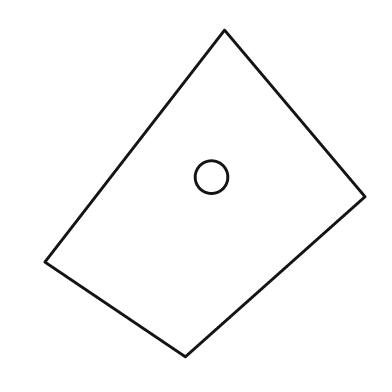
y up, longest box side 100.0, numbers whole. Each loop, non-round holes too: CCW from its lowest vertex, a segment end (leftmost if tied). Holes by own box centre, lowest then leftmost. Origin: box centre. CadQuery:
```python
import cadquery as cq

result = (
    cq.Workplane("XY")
    .moveTo(-6.0, -50.0)
    .lineTo(49.0, -1.0)
    .lineTo(6.0, 50.0)
    .lineTo(-49.0, -21.0)
    .close()
    .moveTo(2.0, 5.0)
    .circle(5.0)
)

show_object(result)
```